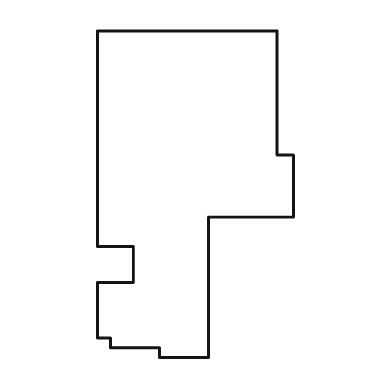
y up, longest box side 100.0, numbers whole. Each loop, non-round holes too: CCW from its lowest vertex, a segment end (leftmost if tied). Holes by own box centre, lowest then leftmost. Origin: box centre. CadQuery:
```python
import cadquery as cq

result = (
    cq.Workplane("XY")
    .moveTo(-11.0, -50.0)
    .lineTo(4.0, -50.0)
    .lineTo(4.0, -7.0)
    .lineTo(30.0, -7.0)
    .lineTo(30.0, 12.0)
    .lineTo(25.0, 12.0)
    .lineTo(25.0, 50.0)
    .lineTo(-30.0, 50.0)
    .lineTo(-30.0, -16.0)
    .lineTo(-19.0, -16.0)
    .lineTo(-19.0, -27.0)
    .lineTo(-30.0, -27.0)
    .lineTo(-30.0, -44.0)
    .lineTo(-26.0, -44.0)
    .lineTo(-26.0, -47.0)
    .lineTo(-11.0, -47.0)
    .close()
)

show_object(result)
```